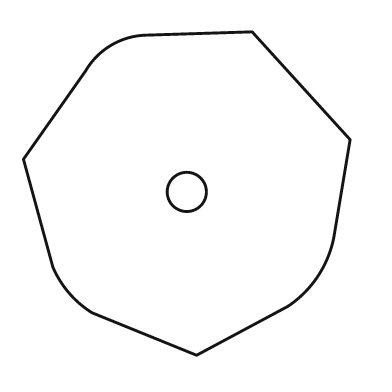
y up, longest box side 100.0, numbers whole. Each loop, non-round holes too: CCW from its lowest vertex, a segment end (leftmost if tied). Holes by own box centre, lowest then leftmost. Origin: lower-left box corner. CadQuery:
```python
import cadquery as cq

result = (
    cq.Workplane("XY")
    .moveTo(53.0, 0.0)
    .lineTo(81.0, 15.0)
    .threePointArc((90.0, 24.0), (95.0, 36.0))
    .lineTo(100.0, 66.0)
    .lineTo(70.0, 99.0)
    .lineTo(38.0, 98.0)
    .threePointArc((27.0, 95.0), (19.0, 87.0))
    .lineTo(0.0, 60.0)
    .lineTo(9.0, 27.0)
    .threePointArc((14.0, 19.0), (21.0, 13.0))
    .close()
    .moveTo(50.0, 50.0)
    .circle(6.0)
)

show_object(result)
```